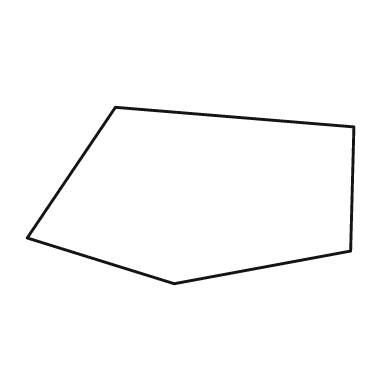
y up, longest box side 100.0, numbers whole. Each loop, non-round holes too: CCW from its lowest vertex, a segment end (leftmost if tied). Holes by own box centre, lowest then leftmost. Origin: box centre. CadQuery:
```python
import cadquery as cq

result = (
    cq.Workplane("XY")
    .moveTo(-5.0, -27.0)
    .lineTo(49.0, -17.0)
    .lineTo(50.0, 21.0)
    .lineTo(-23.0, 27.0)
    .lineTo(-50.0, -13.0)
    .close()
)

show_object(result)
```